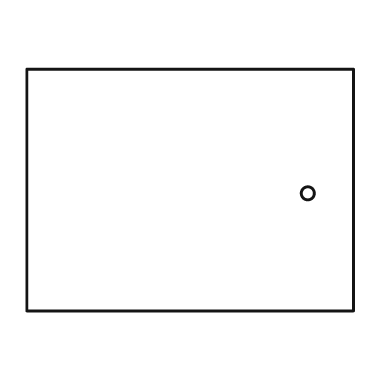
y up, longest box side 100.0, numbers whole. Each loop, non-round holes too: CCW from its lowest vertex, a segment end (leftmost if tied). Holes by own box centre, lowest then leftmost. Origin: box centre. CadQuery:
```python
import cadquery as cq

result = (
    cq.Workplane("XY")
    .moveTo(-50.0, -37.0)
    .lineTo(50.0, -37.0)
    .lineTo(50.0, 37.0)
    .lineTo(-50.0, 37.0)
    .close()
    .moveTo(36.0, -1.0)
    .circle(2.0)
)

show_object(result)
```